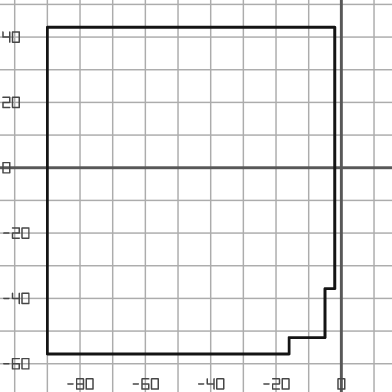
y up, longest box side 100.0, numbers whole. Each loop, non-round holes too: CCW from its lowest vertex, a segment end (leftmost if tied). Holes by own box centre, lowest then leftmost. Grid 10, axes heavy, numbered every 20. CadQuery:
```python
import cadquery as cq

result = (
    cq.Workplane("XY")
    .moveTo(-90.0, -57.0)
    .lineTo(-16.0, -57.0)
    .lineTo(-16.0, -52.0)
    .lineTo(-5.0, -52.0)
    .lineTo(-5.0, -37.0)
    .lineTo(-2.0, -37.0)
    .lineTo(-2.0, 43.0)
    .lineTo(-90.0, 43.0)
    .close()
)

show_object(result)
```